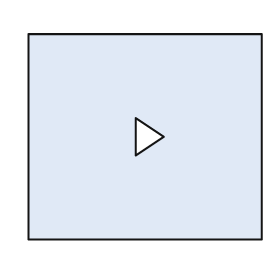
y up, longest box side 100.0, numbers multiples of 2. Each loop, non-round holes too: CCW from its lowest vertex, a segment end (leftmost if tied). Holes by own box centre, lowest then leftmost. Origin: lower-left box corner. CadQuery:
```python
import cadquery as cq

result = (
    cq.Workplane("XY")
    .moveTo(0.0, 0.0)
    .lineTo(100.0, 0.0)
    .lineTo(100.0, 88.0)
    .lineTo(0.0, 88.0)
    .close()
    .moveTo(46.0, 36.0)
    .lineTo(58.0, 44.0)
    .lineTo(46.0, 52.0)
    .close()
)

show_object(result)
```